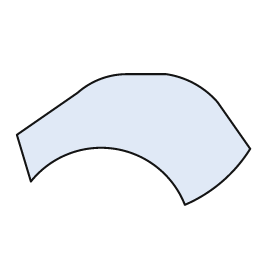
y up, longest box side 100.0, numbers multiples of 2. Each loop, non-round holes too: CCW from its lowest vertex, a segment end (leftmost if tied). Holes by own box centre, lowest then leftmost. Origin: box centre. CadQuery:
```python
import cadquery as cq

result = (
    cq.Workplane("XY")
    .moveTo(22.0, -28.0)
    .threePointArc((38.0, -18.0), (50.0, -4.0))
    .lineTo(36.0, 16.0)
    .threePointArc((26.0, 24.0), (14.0, 28.0))
    .lineTo(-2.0, 28.0)
    .threePointArc((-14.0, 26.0), (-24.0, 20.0))
    .lineTo(-50.0, 2.0)
    .lineTo(-44.0, -18.0)
    .threePointArc((-8.0, -4.0), (22.0, -28.0))
    .close()
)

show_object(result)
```